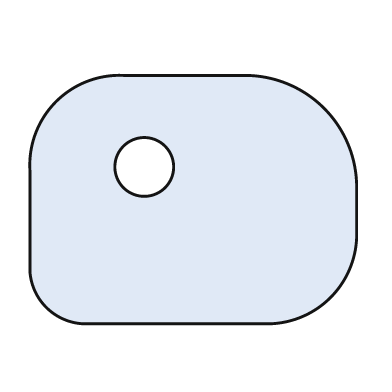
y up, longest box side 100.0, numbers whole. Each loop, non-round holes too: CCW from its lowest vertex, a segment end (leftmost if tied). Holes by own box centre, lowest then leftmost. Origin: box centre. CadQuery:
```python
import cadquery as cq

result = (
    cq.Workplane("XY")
    .moveTo(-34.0, -38.0)
    .lineTo(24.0, -38.0)
    .threePointArc((42.0, -30.0), (50.0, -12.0))
    .lineTo(50.0, 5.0)
    .threePointArc((40.0, 28.0), (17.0, 38.0))
    .lineTo(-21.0, 38.0)
    .threePointArc((-42.0, 30.0), (-50.0, 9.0))
    .lineTo(-50.0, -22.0)
    .threePointArc((-45.0, -33.0), (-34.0, -38.0))
    .close()
    .moveTo(-15.0, 10.0)
    .circle(9.0)
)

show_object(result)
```